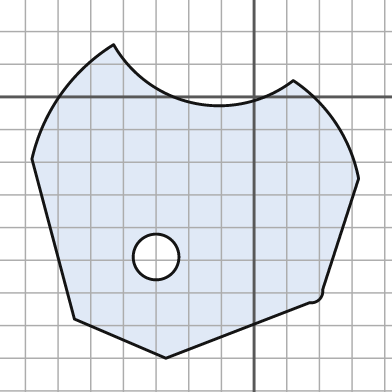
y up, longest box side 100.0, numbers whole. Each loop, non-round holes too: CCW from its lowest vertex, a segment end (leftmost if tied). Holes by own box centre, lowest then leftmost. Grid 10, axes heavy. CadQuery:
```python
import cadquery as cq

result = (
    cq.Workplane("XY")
    .moveTo(-27.0, -80.0)
    .lineTo(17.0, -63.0)
    .threePointArc((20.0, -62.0), (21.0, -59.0))
    .lineTo(32.0, -25.0)
    .threePointArc((25.0, -8.0), (12.0, 5.0))
    .threePointArc((-18.0, -2.0), (-43.0, 16.0))
    .threePointArc((-59.0, 1.0), (-68.0, -19.0))
    .lineTo(-55.0, -68.0)
    .close()
    .moveTo(-30.0, -49.0)
    .circle(7.0)
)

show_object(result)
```